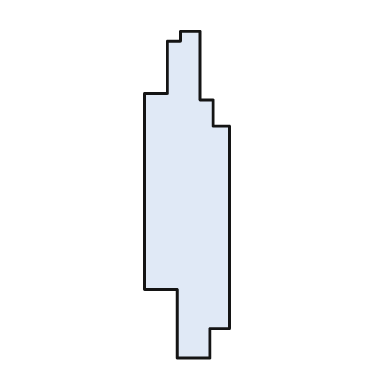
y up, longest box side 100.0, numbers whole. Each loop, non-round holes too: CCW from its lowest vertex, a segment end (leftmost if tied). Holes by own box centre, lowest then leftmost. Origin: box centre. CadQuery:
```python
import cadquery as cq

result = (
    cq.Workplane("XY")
    .moveTo(-3.0, -50.0)
    .lineTo(7.0, -50.0)
    .lineTo(7.0, -41.0)
    .lineTo(13.0, -41.0)
    .lineTo(13.0, 21.0)
    .lineTo(8.0, 21.0)
    .lineTo(8.0, 29.0)
    .lineTo(4.0, 29.0)
    .lineTo(4.0, 50.0)
    .lineTo(-2.0, 50.0)
    .lineTo(-2.0, 47.0)
    .lineTo(-6.0, 47.0)
    .lineTo(-6.0, 31.0)
    .lineTo(-13.0, 31.0)
    .lineTo(-13.0, -29.0)
    .lineTo(-3.0, -29.0)
    .close()
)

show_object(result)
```